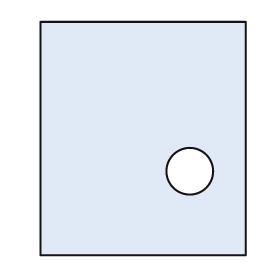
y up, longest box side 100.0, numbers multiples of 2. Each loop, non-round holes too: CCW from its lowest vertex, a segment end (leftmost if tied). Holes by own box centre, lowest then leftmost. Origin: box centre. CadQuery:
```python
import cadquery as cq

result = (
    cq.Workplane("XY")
    .moveTo(-44.0, -50.0)
    .lineTo(44.0, -50.0)
    .lineTo(44.0, 50.0)
    .lineTo(-44.0, 50.0)
    .close()
    .moveTo(20.0, -14.0)
    .circle(10.0)
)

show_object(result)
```